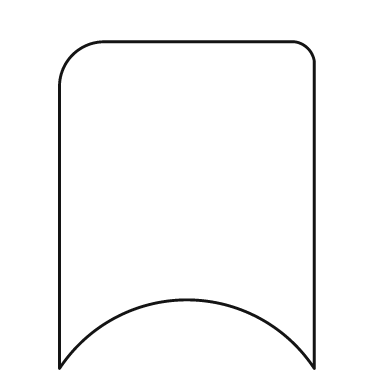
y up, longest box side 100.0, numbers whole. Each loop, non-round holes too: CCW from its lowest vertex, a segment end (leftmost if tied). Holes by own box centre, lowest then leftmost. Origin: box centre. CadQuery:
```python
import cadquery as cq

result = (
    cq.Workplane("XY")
    .moveTo(-39.0, -50.0)
    .threePointArc((0.0, -29.0), (39.0, -50.0))
    .lineTo(39.0, 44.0)
    .threePointArc((37.0, 48.0), (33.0, 50.0))
    .lineTo(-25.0, 50.0)
    .threePointArc((-35.0, 46.0), (-39.0, 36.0))
    .close()
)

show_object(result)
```